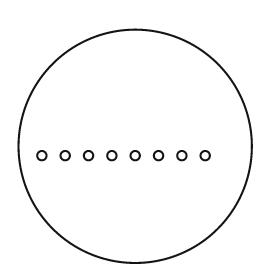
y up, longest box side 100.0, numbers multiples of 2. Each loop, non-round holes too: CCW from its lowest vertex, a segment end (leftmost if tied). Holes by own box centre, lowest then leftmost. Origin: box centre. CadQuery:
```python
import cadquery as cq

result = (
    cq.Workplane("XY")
    .moveTo(0.0, 0.0)
    .circle(50.0)
    .moveTo(-40.0, -4.0)
    .circle(2.0)
    .moveTo(-30.0, -4.0)
    .circle(2.0)
    .moveTo(-20.0, -4.0)
    .circle(2.0)
    .moveTo(-10.0, -4.0)
    .circle(2.0)
    .moveTo(0.0, -4.0)
    .circle(2.0)
    .moveTo(10.0, -4.0)
    .circle(2.0)
    .moveTo(20.0, -4.0)
    .circle(2.0)
    .moveTo(30.0, -4.0)
    .circle(2.0)
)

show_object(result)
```